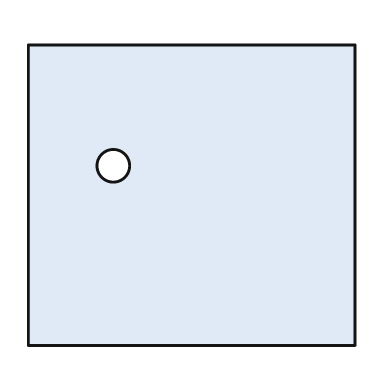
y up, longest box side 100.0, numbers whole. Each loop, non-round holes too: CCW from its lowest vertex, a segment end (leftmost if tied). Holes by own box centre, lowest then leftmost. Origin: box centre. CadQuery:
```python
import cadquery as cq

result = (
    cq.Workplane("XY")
    .moveTo(-50.0, -46.0)
    .lineTo(50.0, -46.0)
    .lineTo(50.0, 46.0)
    .lineTo(-50.0, 46.0)
    .close()
    .moveTo(-24.0, 9.0)
    .circle(5.0)
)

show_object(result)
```